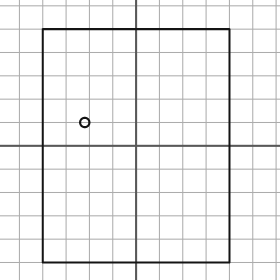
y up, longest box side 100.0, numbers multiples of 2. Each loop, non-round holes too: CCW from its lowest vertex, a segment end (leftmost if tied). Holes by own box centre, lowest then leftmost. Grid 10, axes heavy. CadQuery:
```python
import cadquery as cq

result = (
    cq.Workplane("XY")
    .moveTo(-40.0, -50.0)
    .lineTo(40.0, -50.0)
    .lineTo(40.0, 50.0)
    .lineTo(-40.0, 50.0)
    .close()
    .moveTo(-22.0, 10.0)
    .circle(2.0)
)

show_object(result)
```